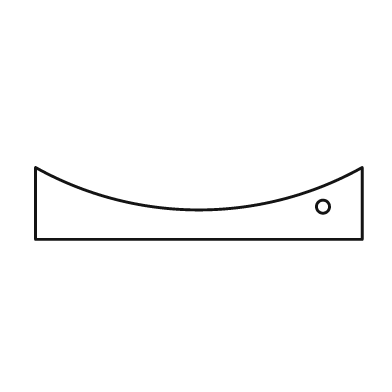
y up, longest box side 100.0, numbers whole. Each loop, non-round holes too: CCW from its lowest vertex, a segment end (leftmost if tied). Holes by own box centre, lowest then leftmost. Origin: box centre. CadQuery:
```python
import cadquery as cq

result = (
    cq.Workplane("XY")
    .moveTo(-50.0, -11.0)
    .lineTo(50.0, -11.0)
    .lineTo(50.0, 11.0)
    .threePointArc((0.0, -2.0), (-50.0, 11.0))
    .close()
    .moveTo(38.0, -1.0)
    .circle(2.0)
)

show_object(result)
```